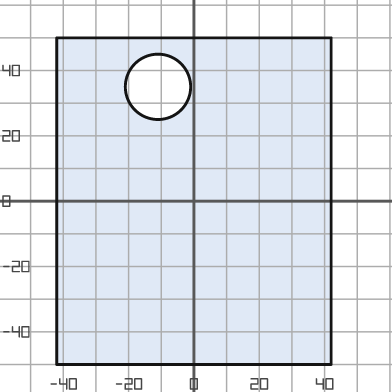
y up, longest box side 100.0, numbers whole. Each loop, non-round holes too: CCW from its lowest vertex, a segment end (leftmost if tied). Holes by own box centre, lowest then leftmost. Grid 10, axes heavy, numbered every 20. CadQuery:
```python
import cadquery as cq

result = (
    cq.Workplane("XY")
    .moveTo(-42.0, -50.0)
    .lineTo(42.0, -50.0)
    .lineTo(42.0, 50.0)
    .lineTo(-42.0, 50.0)
    .close()
    .moveTo(-11.0, 35.0)
    .circle(10.0)
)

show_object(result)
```